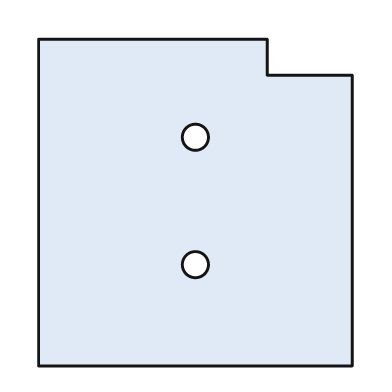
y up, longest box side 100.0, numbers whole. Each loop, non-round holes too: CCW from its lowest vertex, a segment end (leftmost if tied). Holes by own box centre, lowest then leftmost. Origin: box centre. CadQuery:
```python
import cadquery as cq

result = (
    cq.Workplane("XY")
    .moveTo(-48.0, -50.0)
    .lineTo(48.0, -50.0)
    .lineTo(48.0, 39.0)
    .lineTo(22.0, 39.0)
    .lineTo(22.0, 50.0)
    .lineTo(-48.0, 50.0)
    .close()
    .moveTo(0.0, -19.0)
    .circle(4.0)
    .moveTo(0.0, 20.0)
    .circle(4.0)
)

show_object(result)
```